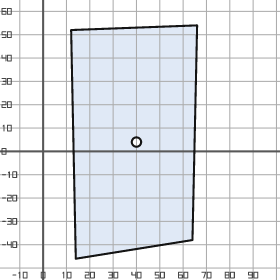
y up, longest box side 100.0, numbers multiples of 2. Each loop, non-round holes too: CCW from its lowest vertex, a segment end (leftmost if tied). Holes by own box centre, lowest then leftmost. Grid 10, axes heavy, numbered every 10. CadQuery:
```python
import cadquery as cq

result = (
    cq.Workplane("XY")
    .moveTo(14.0, -46.0)
    .lineTo(64.0, -38.0)
    .lineTo(66.0, 54.0)
    .lineTo(12.0, 52.0)
    .close()
    .moveTo(40.0, 4.0)
    .circle(2.0)
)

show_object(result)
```